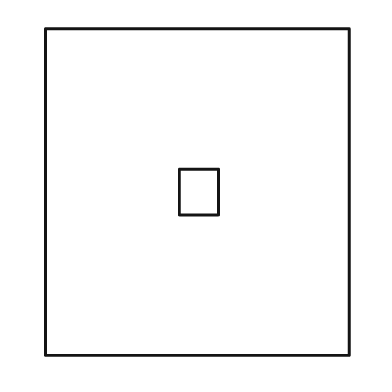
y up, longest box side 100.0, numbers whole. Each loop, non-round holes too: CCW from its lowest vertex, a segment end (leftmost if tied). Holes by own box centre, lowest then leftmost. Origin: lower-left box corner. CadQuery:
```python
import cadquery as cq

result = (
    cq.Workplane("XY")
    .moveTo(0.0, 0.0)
    .lineTo(93.0, 0.0)
    .lineTo(93.0, 100.0)
    .lineTo(0.0, 100.0)
    .close()
    .moveTo(41.0, 43.0)
    .lineTo(53.0, 43.0)
    .lineTo(53.0, 57.0)
    .lineTo(41.0, 57.0)
    .close()
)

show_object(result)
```